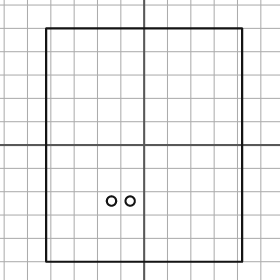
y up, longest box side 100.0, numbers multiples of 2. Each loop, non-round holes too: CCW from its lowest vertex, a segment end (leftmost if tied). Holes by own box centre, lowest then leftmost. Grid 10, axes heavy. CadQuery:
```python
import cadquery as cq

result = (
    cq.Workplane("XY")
    .moveTo(-42.0, -50.0)
    .lineTo(42.0, -50.0)
    .lineTo(42.0, 50.0)
    .lineTo(-42.0, 50.0)
    .close()
    .moveTo(-14.0, -24.0)
    .circle(2.0)
    .moveTo(-6.0, -24.0)
    .circle(2.0)
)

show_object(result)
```